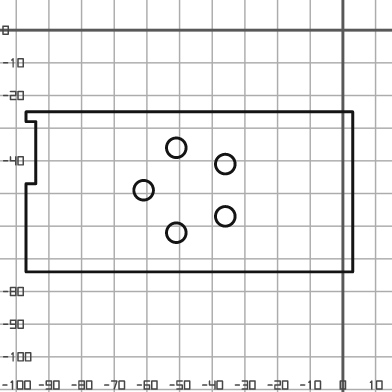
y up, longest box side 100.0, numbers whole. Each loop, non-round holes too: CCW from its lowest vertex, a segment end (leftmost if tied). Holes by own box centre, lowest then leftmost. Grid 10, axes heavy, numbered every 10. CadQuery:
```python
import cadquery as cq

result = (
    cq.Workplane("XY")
    .moveTo(-97.0, -74.0)
    .lineTo(3.0, -74.0)
    .lineTo(3.0, -25.0)
    .lineTo(-97.0, -25.0)
    .lineTo(-97.0, -28.0)
    .lineTo(-94.0, -28.0)
    .lineTo(-94.0, -47.0)
    .lineTo(-97.0, -47.0)
    .close()
    .moveTo(-51.0, -62.0)
    .circle(3.0)
    .moveTo(-36.0, -57.0)
    .circle(3.0)
    .moveTo(-61.0, -49.0)
    .circle(3.0)
    .moveTo(-36.0, -41.0)
    .circle(3.0)
    .moveTo(-51.0, -36.0)
    .circle(3.0)
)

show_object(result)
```